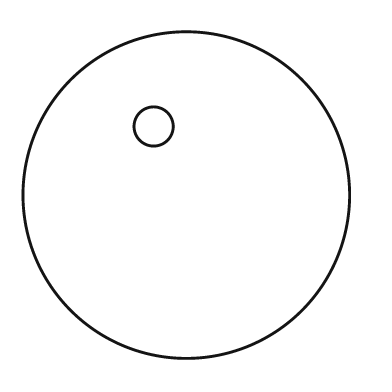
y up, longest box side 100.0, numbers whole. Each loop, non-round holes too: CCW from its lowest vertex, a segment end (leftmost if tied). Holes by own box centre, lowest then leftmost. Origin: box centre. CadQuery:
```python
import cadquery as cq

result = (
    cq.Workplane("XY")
    .moveTo(0.0, 0.0)
    .circle(50.0)
    .moveTo(-10.0, 21.0)
    .circle(6.0)
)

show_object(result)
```